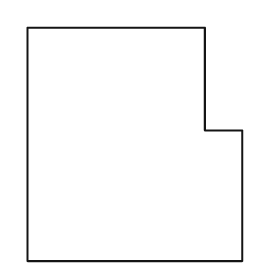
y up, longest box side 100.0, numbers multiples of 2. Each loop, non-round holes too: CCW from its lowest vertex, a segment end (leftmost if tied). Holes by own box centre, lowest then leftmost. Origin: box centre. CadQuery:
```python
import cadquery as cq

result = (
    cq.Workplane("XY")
    .moveTo(-46.0, -50.0)
    .lineTo(46.0, -50.0)
    .lineTo(46.0, 6.0)
    .lineTo(30.0, 6.0)
    .lineTo(30.0, 50.0)
    .lineTo(-46.0, 50.0)
    .close()
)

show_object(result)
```